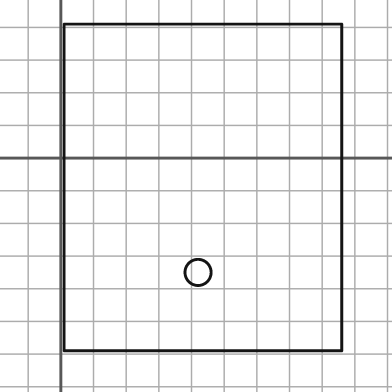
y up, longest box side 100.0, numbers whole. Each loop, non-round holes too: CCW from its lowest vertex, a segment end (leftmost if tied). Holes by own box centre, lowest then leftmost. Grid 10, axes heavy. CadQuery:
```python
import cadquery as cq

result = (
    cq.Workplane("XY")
    .moveTo(1.0, -59.0)
    .lineTo(86.0, -59.0)
    .lineTo(86.0, 41.0)
    .lineTo(1.0, 41.0)
    .close()
    .moveTo(42.0, -35.0)
    .circle(4.0)
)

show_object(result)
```